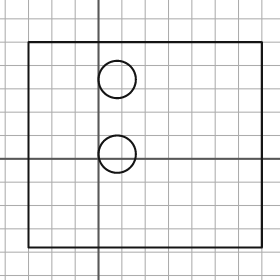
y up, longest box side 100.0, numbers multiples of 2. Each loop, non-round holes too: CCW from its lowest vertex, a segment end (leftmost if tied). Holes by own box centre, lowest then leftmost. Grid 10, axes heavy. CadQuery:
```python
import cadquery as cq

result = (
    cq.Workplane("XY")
    .moveTo(-30.0, -38.0)
    .lineTo(70.0, -38.0)
    .lineTo(70.0, 50.0)
    .lineTo(-30.0, 50.0)
    .close()
    .moveTo(8.0, 2.0)
    .circle(8.0)
    .moveTo(8.0, 34.0)
    .circle(8.0)
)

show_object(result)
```